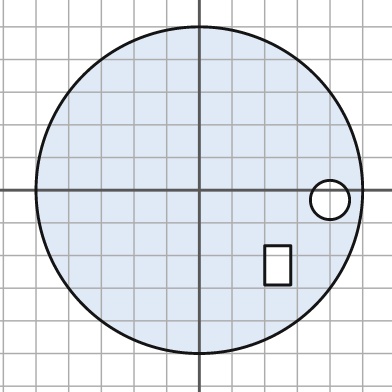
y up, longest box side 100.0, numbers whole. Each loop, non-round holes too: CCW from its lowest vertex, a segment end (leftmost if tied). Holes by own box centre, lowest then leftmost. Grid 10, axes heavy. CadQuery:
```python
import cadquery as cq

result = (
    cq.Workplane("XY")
    .moveTo(0.0, 0.0)
    .circle(50.0)
    .moveTo(20.0, -29.0)
    .lineTo(28.0, -29.0)
    .lineTo(28.0, -17.0)
    .lineTo(20.0, -17.0)
    .close()
    .moveTo(40.0, -3.0)
    .circle(6.0)
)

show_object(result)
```